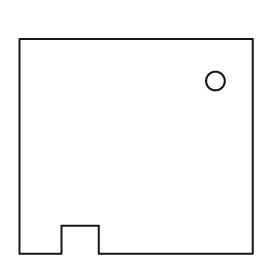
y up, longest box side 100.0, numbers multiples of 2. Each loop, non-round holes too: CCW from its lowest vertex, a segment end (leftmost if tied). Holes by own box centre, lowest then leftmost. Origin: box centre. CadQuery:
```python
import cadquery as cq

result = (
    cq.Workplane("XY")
    .moveTo(-50.0, -46.0)
    .lineTo(-32.0, -46.0)
    .lineTo(-32.0, -34.0)
    .lineTo(-16.0, -34.0)
    .lineTo(-16.0, -46.0)
    .lineTo(50.0, -46.0)
    .lineTo(50.0, 46.0)
    .lineTo(-50.0, 46.0)
    .close()
    .moveTo(34.0, 28.0)
    .circle(4.0)
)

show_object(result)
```